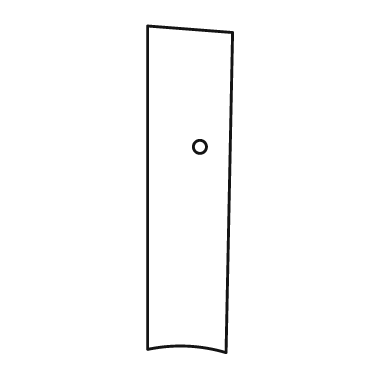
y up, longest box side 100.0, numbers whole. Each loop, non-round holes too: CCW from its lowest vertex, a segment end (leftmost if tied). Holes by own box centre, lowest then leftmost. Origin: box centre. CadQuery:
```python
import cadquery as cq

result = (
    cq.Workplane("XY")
    .moveTo(11.0, -50.0)
    .lineTo(13.0, 48.0)
    .lineTo(-13.0, 50.0)
    .lineTo(-13.0, -49.0)
    .threePointArc((-1.0, -48.0), (11.0, -50.0))
    .close()
    .moveTo(3.0, 13.0)
    .circle(2.0)
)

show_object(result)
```